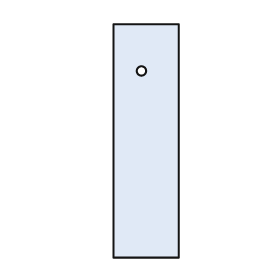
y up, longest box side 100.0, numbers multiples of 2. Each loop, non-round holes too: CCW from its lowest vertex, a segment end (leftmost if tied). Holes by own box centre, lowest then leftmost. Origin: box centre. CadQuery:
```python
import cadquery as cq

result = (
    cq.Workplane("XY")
    .moveTo(-14.0, -50.0)
    .lineTo(14.0, -50.0)
    .lineTo(14.0, 50.0)
    .lineTo(-14.0, 50.0)
    .close()
    .moveTo(-2.0, 30.0)
    .circle(2.0)
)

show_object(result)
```